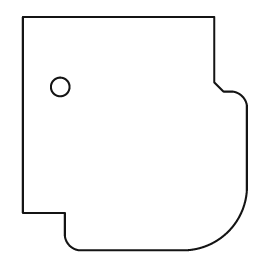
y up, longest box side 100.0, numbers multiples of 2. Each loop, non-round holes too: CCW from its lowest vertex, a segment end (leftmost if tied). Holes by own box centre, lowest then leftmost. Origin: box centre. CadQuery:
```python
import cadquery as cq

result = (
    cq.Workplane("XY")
    .moveTo(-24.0, -50.0)
    .lineTo(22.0, -50.0)
    .threePointArc((40.0, -42.0), (48.0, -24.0))
    .lineTo(48.0, 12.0)
    .threePointArc((46.0, 16.0), (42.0, 18.0))
    .lineTo(38.0, 18.0)
    .lineTo(34.0, 22.0)
    .lineTo(34.0, 50.0)
    .lineTo(-48.0, 50.0)
    .lineTo(-48.0, -34.0)
    .lineTo(-30.0, -34.0)
    .lineTo(-30.0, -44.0)
    .threePointArc((-28.0, -48.0), (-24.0, -50.0))
    .close()
    .moveTo(-32.0, 20.0)
    .circle(4.0)
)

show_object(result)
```